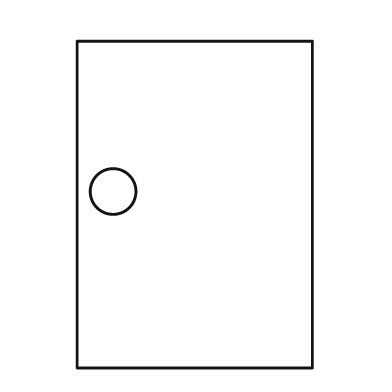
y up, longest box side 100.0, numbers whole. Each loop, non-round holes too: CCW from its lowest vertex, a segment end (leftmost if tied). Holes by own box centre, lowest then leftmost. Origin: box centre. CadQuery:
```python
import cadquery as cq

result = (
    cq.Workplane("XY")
    .moveTo(-36.0, -50.0)
    .lineTo(36.0, -50.0)
    .lineTo(36.0, 50.0)
    .lineTo(-36.0, 50.0)
    .close()
    .moveTo(-25.0, 4.0)
    .circle(7.0)
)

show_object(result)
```